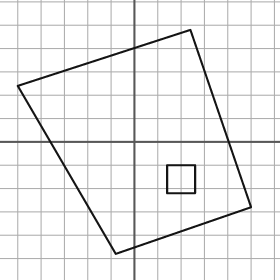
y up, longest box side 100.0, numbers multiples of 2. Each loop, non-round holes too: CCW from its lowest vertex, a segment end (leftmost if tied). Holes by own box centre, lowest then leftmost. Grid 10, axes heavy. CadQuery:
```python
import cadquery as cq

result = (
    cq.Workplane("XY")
    .moveTo(-8.0, -48.0)
    .lineTo(50.0, -28.0)
    .lineTo(24.0, 48.0)
    .lineTo(-50.0, 24.0)
    .close()
    .moveTo(14.0, -22.0)
    .lineTo(26.0, -22.0)
    .lineTo(26.0, -10.0)
    .lineTo(14.0, -10.0)
    .close()
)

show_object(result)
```